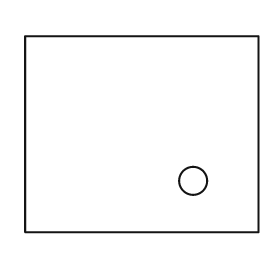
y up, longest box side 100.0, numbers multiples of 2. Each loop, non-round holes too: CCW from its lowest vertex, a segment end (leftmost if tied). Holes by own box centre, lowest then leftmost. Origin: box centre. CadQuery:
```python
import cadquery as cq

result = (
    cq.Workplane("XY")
    .moveTo(-50.0, -42.0)
    .lineTo(50.0, -42.0)
    .lineTo(50.0, 42.0)
    .lineTo(-50.0, 42.0)
    .close()
    .moveTo(22.0, -20.0)
    .circle(6.0)
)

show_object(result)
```